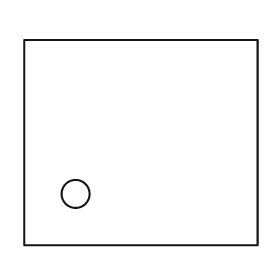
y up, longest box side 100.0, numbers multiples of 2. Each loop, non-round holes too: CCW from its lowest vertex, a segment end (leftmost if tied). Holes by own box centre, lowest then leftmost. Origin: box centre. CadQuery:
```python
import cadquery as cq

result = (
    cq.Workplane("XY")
    .moveTo(-50.0, -44.0)
    .lineTo(50.0, -44.0)
    .lineTo(50.0, 44.0)
    .lineTo(-50.0, 44.0)
    .close()
    .moveTo(-28.0, -22.0)
    .circle(6.0)
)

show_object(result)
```